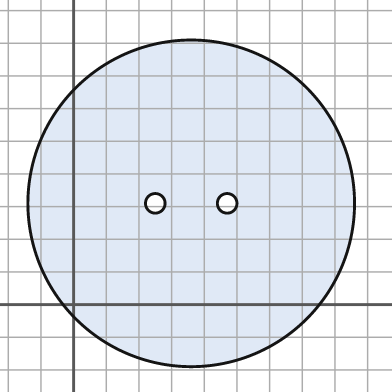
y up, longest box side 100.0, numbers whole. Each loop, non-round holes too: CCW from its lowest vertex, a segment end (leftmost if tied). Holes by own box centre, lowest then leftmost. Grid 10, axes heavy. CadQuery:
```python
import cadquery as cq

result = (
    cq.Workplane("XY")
    .moveTo(36.0, 31.0)
    .circle(50.0)
    .moveTo(25.0, 31.0)
    .circle(3.0)
    .moveTo(47.0, 31.0)
    .circle(3.0)
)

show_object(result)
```